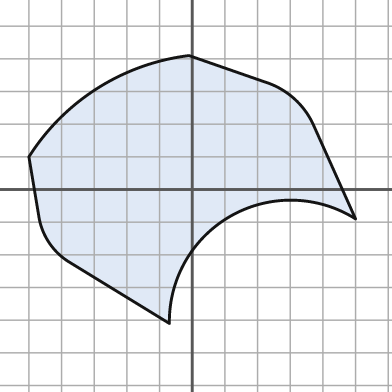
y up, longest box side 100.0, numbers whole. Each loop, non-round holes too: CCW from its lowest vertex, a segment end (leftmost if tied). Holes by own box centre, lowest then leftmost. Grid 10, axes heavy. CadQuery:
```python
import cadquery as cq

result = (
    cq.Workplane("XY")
    .moveTo(-7.0, -41.0)
    .threePointArc((12.0, -8.0), (50.0, -9.0))
    .lineTo(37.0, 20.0)
    .threePointArc((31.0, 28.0), (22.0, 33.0))
    .lineTo(-1.0, 41.0)
    .threePointArc((-29.0, 31.0), (-50.0, 10.0))
    .lineTo(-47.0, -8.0)
    .threePointArc((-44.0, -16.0), (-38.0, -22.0))
    .close()
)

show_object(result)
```